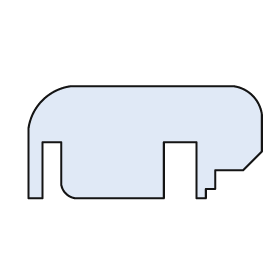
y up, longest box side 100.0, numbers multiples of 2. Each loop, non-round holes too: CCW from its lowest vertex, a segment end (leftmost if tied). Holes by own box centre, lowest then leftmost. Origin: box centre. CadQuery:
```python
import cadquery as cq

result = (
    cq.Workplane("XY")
    .moveTo(-50.0, -24.0)
    .lineTo(-44.0, -24.0)
    .lineTo(-44.0, 0.0)
    .lineTo(-36.0, 0.0)
    .lineTo(-36.0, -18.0)
    .threePointArc((-34.0, -22.0), (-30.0, -24.0))
    .lineTo(8.0, -24.0)
    .lineTo(8.0, 0.0)
    .lineTo(22.0, 0.0)
    .lineTo(22.0, -24.0)
    .lineTo(26.0, -24.0)
    .lineTo(26.0, -20.0)
    .lineTo(30.0, -20.0)
    .lineTo(30.0, -12.0)
    .lineTo(42.0, -12.0)
    .lineTo(50.0, -4.0)
    .lineTo(50.0, 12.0)
    .threePointArc((46.0, 20.0), (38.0, 24.0))
    .lineTo(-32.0, 24.0)
    .threePointArc((-44.0, 18.0), (-50.0, 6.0))
    .close()
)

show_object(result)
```